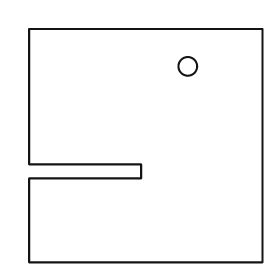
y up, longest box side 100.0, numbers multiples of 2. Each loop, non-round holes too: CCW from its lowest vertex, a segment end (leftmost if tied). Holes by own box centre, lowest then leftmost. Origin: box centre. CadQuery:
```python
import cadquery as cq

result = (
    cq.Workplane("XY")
    .moveTo(-50.0, -50.0)
    .lineTo(50.0, -50.0)
    .lineTo(50.0, 50.0)
    .lineTo(-50.0, 50.0)
    .lineTo(-50.0, -8.0)
    .lineTo(-2.0, -8.0)
    .lineTo(-2.0, -14.0)
    .lineTo(-50.0, -14.0)
    .close()
    .moveTo(18.0, 34.0)
    .circle(4.0)
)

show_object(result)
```